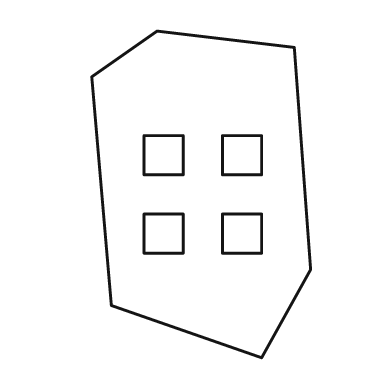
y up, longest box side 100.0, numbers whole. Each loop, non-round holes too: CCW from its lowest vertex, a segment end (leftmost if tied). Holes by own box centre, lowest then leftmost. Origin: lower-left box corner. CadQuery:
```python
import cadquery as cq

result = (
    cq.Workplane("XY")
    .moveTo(52.0, 0.0)
    .lineTo(67.0, 27.0)
    .lineTo(62.0, 95.0)
    .lineTo(20.0, 100.0)
    .lineTo(0.0, 86.0)
    .lineTo(6.0, 16.0)
    .close()
    .moveTo(16.0, 32.0)
    .lineTo(28.0, 32.0)
    .lineTo(28.0, 44.0)
    .lineTo(16.0, 44.0)
    .close()
    .moveTo(40.0, 32.0)
    .lineTo(52.0, 32.0)
    .lineTo(52.0, 44.0)
    .lineTo(40.0, 44.0)
    .close()
    .moveTo(16.0, 56.0)
    .lineTo(28.0, 56.0)
    .lineTo(28.0, 68.0)
    .lineTo(16.0, 68.0)
    .close()
    .moveTo(40.0, 56.0)
    .lineTo(52.0, 56.0)
    .lineTo(52.0, 68.0)
    .lineTo(40.0, 68.0)
    .close()
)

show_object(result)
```